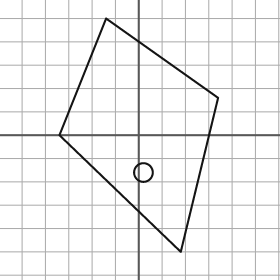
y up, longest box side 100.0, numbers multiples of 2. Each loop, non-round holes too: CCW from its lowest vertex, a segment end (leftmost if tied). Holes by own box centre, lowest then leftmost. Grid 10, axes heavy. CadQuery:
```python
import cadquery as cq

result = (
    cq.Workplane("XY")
    .moveTo(18.0, -50.0)
    .lineTo(34.0, 16.0)
    .lineTo(-14.0, 50.0)
    .lineTo(-34.0, 0.0)
    .close()
    .moveTo(2.0, -16.0)
    .circle(4.0)
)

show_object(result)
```